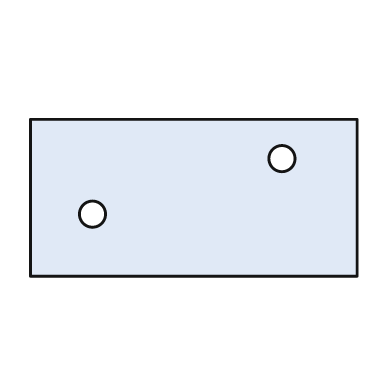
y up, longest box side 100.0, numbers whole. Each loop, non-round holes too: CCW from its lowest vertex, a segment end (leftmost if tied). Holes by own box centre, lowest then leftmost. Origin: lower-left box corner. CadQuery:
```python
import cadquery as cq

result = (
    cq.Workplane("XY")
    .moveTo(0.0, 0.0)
    .lineTo(100.0, 0.0)
    .lineTo(100.0, 48.0)
    .lineTo(0.0, 48.0)
    .close()
    .moveTo(19.0, 19.0)
    .circle(4.0)
    .moveTo(77.0, 36.0)
    .circle(4.0)
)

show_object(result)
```